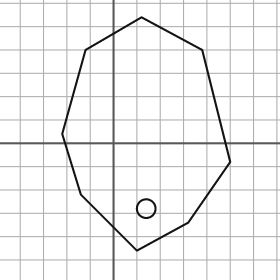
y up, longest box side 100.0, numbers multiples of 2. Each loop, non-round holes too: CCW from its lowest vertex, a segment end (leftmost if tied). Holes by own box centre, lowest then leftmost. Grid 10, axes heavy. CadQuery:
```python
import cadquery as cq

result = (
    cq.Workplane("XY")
    .moveTo(10.0, -46.0)
    .lineTo(32.0, -34.0)
    .lineTo(50.0, -8.0)
    .lineTo(38.0, 40.0)
    .lineTo(12.0, 54.0)
    .lineTo(-12.0, 40.0)
    .lineTo(-22.0, 4.0)
    .lineTo(-14.0, -22.0)
    .close()
    .moveTo(14.0, -28.0)
    .circle(4.0)
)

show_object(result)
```